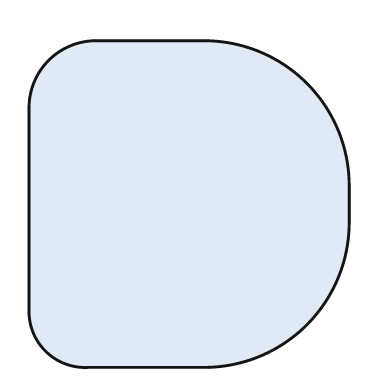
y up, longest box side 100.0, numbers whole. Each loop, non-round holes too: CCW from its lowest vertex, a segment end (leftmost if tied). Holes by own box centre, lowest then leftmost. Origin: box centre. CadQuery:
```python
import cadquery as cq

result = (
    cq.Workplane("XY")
    .moveTo(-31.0, -50.0)
    .lineTo(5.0, -50.0)
    .threePointArc((36.0, -37.0), (49.0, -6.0))
    .lineTo(49.0, 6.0)
    .threePointArc((36.0, 37.0), (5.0, 50.0))
    .lineTo(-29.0, 50.0)
    .threePointArc((-43.0, 44.0), (-49.0, 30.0))
    .lineTo(-49.0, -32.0)
    .threePointArc((-44.0, -45.0), (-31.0, -50.0))
    .close()
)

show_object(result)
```